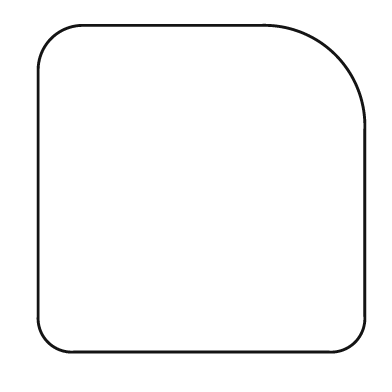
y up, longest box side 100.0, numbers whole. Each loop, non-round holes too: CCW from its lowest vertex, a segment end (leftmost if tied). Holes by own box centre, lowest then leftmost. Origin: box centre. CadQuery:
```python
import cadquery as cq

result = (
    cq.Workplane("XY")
    .moveTo(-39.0, -50.0)
    .lineTo(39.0, -50.0)
    .threePointArc((47.0, -47.0), (50.0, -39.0))
    .lineTo(50.0, 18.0)
    .threePointArc((41.0, 41.0), (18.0, 50.0))
    .lineTo(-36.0, 50.0)
    .threePointArc((-46.0, 46.0), (-50.0, 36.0))
    .lineTo(-50.0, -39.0)
    .threePointArc((-47.0, -47.0), (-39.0, -50.0))
    .close()
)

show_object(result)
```